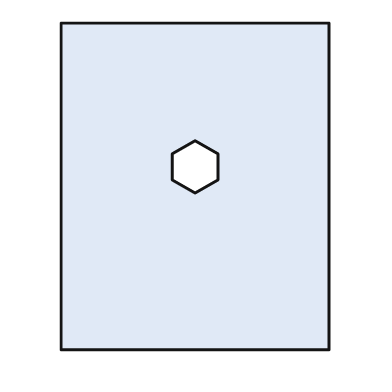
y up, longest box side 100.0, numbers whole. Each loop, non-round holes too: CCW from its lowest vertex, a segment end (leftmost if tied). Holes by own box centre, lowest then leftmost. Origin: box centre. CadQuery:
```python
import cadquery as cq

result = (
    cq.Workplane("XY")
    .moveTo(-41.0, -50.0)
    .lineTo(41.0, -50.0)
    .lineTo(41.0, 50.0)
    .lineTo(-41.0, 50.0)
    .close()
    .moveTo(0.0, -2.0)
    .lineTo(7.0, 2.0)
    .lineTo(7.0, 10.0)
    .lineTo(0.0, 14.0)
    .lineTo(-7.0, 10.0)
    .lineTo(-7.0, 2.0)
    .close()
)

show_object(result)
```